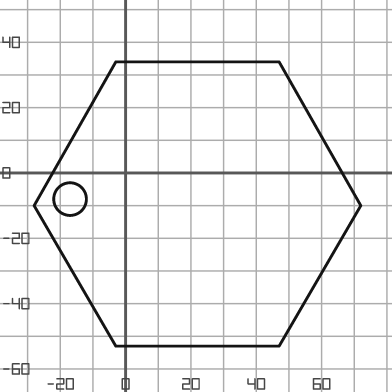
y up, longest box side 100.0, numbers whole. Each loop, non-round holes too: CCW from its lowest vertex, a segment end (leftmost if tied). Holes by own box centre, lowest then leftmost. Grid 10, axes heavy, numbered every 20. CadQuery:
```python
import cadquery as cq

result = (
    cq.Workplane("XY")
    .moveTo(-3.0, -53.0)
    .lineTo(47.0, -53.0)
    .lineTo(72.0, -10.0)
    .lineTo(47.0, 34.0)
    .lineTo(-3.0, 34.0)
    .lineTo(-28.0, -10.0)
    .close()
    .moveTo(-17.0, -8.0)
    .circle(5.0)
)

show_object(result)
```